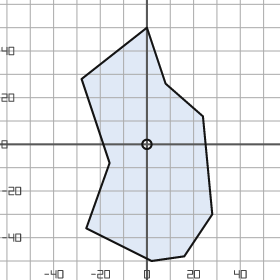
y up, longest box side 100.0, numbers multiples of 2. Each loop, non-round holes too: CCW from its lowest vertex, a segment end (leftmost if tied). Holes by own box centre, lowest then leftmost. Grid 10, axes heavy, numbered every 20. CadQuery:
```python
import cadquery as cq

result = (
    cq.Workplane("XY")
    .moveTo(2.0, -50.0)
    .lineTo(16.0, -48.0)
    .lineTo(28.0, -30.0)
    .lineTo(24.0, 12.0)
    .lineTo(8.0, 26.0)
    .lineTo(0.0, 50.0)
    .lineTo(-28.0, 28.0)
    .lineTo(-16.0, -8.0)
    .lineTo(-26.0, -36.0)
    .close()
    .moveTo(0.0, 0.0)
    .circle(2.0)
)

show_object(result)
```